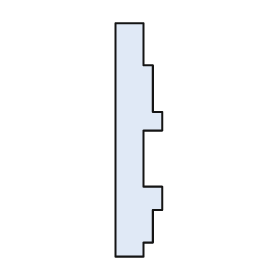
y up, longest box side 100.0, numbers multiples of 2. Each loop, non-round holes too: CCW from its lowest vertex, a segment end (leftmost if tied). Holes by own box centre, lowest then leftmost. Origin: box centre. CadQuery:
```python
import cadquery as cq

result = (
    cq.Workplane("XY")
    .moveTo(-10.0, -50.0)
    .lineTo(2.0, -50.0)
    .lineTo(2.0, -44.0)
    .lineTo(6.0, -44.0)
    .lineTo(6.0, -30.0)
    .lineTo(10.0, -30.0)
    .lineTo(10.0, -20.0)
    .lineTo(2.0, -20.0)
    .lineTo(2.0, 4.0)
    .lineTo(10.0, 4.0)
    .lineTo(10.0, 12.0)
    .lineTo(6.0, 12.0)
    .lineTo(6.0, 32.0)
    .lineTo(2.0, 32.0)
    .lineTo(2.0, 50.0)
    .lineTo(-10.0, 50.0)
    .close()
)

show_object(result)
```